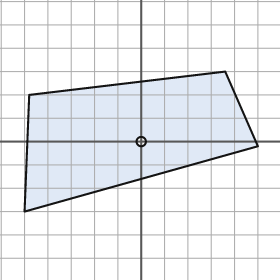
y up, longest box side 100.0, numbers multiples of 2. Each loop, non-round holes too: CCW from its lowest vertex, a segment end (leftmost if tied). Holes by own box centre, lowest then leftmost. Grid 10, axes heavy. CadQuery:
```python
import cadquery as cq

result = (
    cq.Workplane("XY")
    .moveTo(-50.0, -30.0)
    .lineTo(50.0, -2.0)
    .lineTo(36.0, 30.0)
    .lineTo(-48.0, 20.0)
    .close()
    .moveTo(0.0, 0.0)
    .circle(2.0)
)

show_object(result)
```